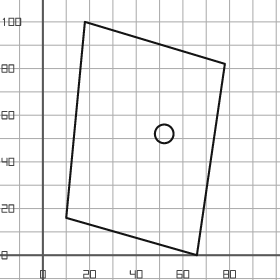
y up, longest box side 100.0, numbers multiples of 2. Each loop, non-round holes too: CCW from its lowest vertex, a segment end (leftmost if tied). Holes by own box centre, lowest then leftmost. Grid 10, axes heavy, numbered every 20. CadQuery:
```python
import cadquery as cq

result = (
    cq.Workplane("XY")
    .moveTo(66.0, 0.0)
    .lineTo(78.0, 82.0)
    .lineTo(18.0, 100.0)
    .lineTo(10.0, 16.0)
    .close()
    .moveTo(52.0, 52.0)
    .circle(4.0)
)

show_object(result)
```